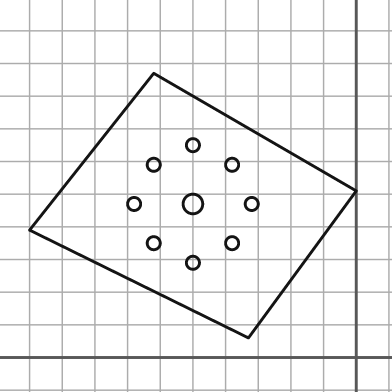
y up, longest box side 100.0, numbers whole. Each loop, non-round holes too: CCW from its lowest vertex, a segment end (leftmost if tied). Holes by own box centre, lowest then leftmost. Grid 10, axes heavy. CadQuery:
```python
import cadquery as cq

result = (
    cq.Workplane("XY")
    .moveTo(-33.0, 6.0)
    .lineTo(0.0, 51.0)
    .lineTo(-62.0, 87.0)
    .lineTo(-100.0, 39.0)
    .close()
    .moveTo(-50.0, 29.0)
    .circle(2.0)
    .moveTo(-62.0, 35.0)
    .circle(2.0)
    .moveTo(-38.0, 35.0)
    .circle(2.0)
    .moveTo(-68.0, 47.0)
    .circle(2.0)
    .moveTo(-50.0, 47.0)
    .circle(3.0)
    .moveTo(-32.0, 47.0)
    .circle(2.0)
    .moveTo(-62.0, 59.0)
    .circle(2.0)
    .moveTo(-38.0, 59.0)
    .circle(2.0)
    .moveTo(-50.0, 65.0)
    .circle(2.0)
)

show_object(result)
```